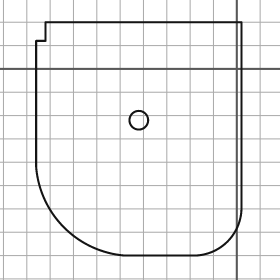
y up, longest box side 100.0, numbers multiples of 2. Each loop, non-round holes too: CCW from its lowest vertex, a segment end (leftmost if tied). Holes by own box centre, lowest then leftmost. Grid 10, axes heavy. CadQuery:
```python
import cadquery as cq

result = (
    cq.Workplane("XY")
    .moveTo(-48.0, -80.0)
    .lineTo(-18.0, -80.0)
    .threePointArc((-4.0, -74.0), (2.0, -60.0))
    .lineTo(2.0, 20.0)
    .lineTo(-82.0, 20.0)
    .lineTo(-82.0, 12.0)
    .lineTo(-86.0, 12.0)
    .lineTo(-86.0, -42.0)
    .threePointArc((-74.0, -68.0), (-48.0, -80.0))
    .close()
    .moveTo(-42.0, -22.0)
    .circle(4.0)
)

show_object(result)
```